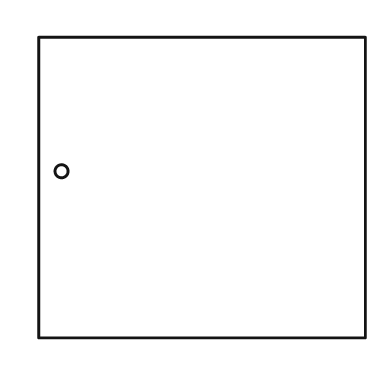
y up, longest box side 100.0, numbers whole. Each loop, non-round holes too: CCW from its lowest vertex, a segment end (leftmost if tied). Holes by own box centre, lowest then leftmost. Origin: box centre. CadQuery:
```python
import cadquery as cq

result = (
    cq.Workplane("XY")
    .moveTo(-50.0, -46.0)
    .lineTo(50.0, -46.0)
    .lineTo(50.0, 46.0)
    .lineTo(-50.0, 46.0)
    .close()
    .moveTo(-43.0, 5.0)
    .circle(2.0)
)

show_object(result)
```